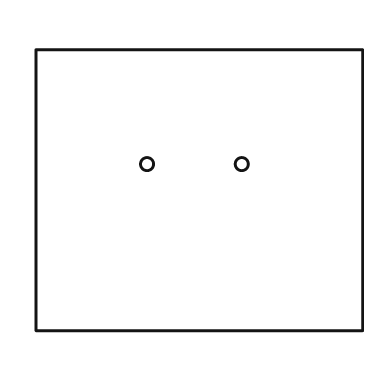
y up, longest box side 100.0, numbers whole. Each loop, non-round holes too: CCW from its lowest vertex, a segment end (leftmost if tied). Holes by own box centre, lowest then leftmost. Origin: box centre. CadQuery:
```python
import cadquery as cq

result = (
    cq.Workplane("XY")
    .moveTo(-50.0, -43.0)
    .lineTo(50.0, -43.0)
    .lineTo(50.0, 43.0)
    .lineTo(-50.0, 43.0)
    .close()
    .moveTo(-16.0, 8.0)
    .circle(2.0)
    .moveTo(13.0, 8.0)
    .circle(2.0)
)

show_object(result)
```